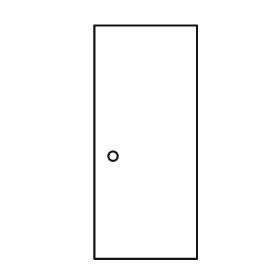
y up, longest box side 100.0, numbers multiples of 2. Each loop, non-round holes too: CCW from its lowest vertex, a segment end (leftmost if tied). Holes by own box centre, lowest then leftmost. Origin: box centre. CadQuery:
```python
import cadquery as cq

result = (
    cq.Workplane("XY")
    .moveTo(-22.0, -50.0)
    .lineTo(22.0, -50.0)
    .lineTo(22.0, 50.0)
    .lineTo(-22.0, 50.0)
    .close()
    .moveTo(-14.0, -6.0)
    .circle(2.0)
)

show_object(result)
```